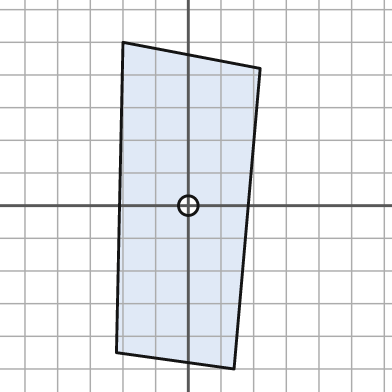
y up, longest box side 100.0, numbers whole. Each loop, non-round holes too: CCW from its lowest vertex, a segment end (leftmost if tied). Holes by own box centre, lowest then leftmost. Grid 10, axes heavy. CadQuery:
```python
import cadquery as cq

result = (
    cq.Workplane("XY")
    .moveTo(14.0, -50.0)
    .lineTo(22.0, 42.0)
    .lineTo(-20.0, 50.0)
    .lineTo(-22.0, -45.0)
    .close()
    .moveTo(0.0, 0.0)
    .circle(3.0)
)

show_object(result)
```